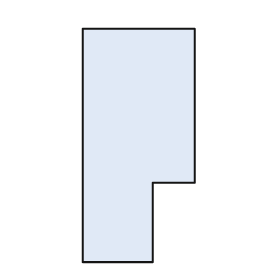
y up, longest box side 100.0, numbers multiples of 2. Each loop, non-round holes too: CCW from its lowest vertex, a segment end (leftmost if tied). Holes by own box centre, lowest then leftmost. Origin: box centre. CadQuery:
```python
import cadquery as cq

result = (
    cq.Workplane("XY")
    .moveTo(-24.0, -50.0)
    .lineTo(6.0, -50.0)
    .lineTo(6.0, -16.0)
    .lineTo(24.0, -16.0)
    .lineTo(24.0, 50.0)
    .lineTo(-24.0, 50.0)
    .close()
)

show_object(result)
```